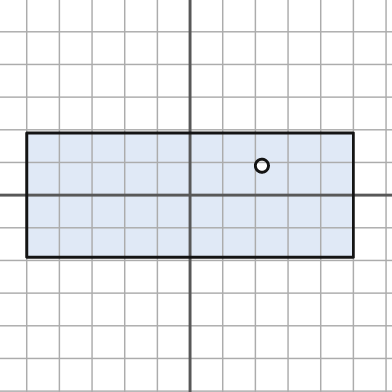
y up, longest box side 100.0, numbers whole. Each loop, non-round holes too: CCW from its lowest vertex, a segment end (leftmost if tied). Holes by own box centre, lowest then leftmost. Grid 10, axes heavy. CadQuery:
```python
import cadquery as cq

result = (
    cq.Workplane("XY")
    .moveTo(-50.0, -19.0)
    .lineTo(50.0, -19.0)
    .lineTo(50.0, 19.0)
    .lineTo(-50.0, 19.0)
    .close()
    .moveTo(22.0, 9.0)
    .circle(2.0)
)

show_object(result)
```